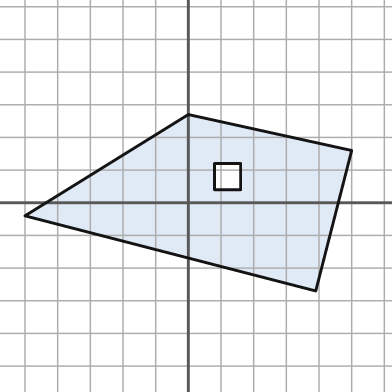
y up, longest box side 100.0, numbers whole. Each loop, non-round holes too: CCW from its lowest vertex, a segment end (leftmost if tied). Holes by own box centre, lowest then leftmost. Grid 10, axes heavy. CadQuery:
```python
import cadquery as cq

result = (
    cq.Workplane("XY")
    .moveTo(39.0, -27.0)
    .lineTo(50.0, 16.0)
    .lineTo(0.0, 27.0)
    .lineTo(-50.0, -4.0)
    .close()
    .moveTo(8.0, 4.0)
    .lineTo(16.0, 4.0)
    .lineTo(16.0, 12.0)
    .lineTo(8.0, 12.0)
    .close()
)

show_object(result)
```